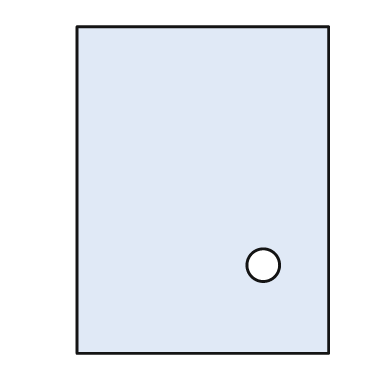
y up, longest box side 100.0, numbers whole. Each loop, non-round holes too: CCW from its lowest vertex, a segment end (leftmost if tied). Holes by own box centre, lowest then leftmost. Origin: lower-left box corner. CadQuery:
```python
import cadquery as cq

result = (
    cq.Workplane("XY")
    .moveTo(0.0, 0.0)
    .lineTo(77.0, 0.0)
    .lineTo(77.0, 100.0)
    .lineTo(0.0, 100.0)
    .close()
    .moveTo(57.0, 27.0)
    .circle(5.0)
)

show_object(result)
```